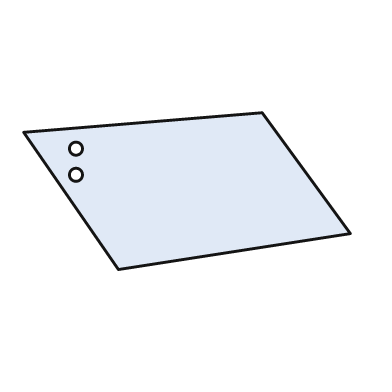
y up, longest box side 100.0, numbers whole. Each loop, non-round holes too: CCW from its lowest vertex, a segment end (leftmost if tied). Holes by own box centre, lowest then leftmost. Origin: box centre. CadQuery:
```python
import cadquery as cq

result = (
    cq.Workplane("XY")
    .moveTo(-21.0, -24.0)
    .lineTo(50.0, -13.0)
    .lineTo(23.0, 24.0)
    .lineTo(-50.0, 18.0)
    .close()
    .moveTo(-34.0, 5.0)
    .circle(2.0)
    .moveTo(-34.0, 13.0)
    .circle(2.0)
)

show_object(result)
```